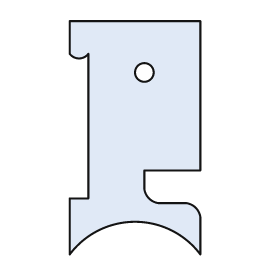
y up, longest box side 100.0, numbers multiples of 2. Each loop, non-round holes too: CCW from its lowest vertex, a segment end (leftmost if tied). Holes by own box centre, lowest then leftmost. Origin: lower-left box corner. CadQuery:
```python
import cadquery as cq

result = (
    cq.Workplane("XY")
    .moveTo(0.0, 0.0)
    .threePointArc((28.0, 14.0), (56.0, 0.0))
    .lineTo(56.0, 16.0)
    .threePointArc((54.0, 20.0), (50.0, 22.0))
    .lineTo(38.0, 22.0)
    .threePointArc((34.0, 24.0), (32.0, 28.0))
    .lineTo(32.0, 36.0)
    .lineTo(56.0, 36.0)
    .lineTo(56.0, 100.0)
    .lineTo(0.0, 100.0)
    .lineTo(0.0, 86.0)
    .threePointArc((4.0, 84.0), (8.0, 86.0))
    .lineTo(8.0, 24.0)
    .lineTo(0.0, 24.0)
    .close()
    .moveTo(32.0, 78.0)
    .circle(4.0)
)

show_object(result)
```